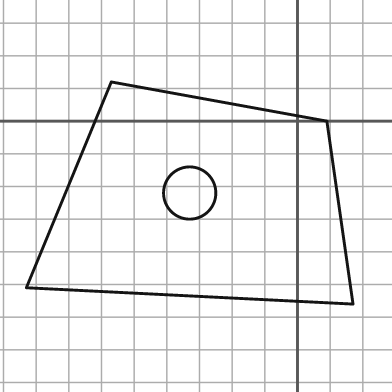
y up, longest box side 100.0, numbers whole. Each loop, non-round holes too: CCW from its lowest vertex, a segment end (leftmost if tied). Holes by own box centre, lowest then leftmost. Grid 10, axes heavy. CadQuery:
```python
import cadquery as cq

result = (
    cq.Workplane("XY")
    .moveTo(17.0, -56.0)
    .lineTo(9.0, 0.0)
    .lineTo(-57.0, 12.0)
    .lineTo(-83.0, -51.0)
    .close()
    .moveTo(-33.0, -22.0)
    .circle(8.0)
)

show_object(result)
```